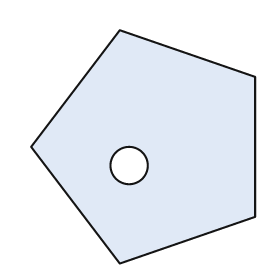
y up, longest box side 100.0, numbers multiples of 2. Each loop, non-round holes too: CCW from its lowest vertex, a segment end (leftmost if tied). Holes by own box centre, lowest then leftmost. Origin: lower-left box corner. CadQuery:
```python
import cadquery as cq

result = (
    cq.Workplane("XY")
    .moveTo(38.0, 0.0)
    .lineTo(96.0, 20.0)
    .lineTo(96.0, 80.0)
    .lineTo(38.0, 100.0)
    .lineTo(0.0, 50.0)
    .close()
    .moveTo(42.0, 42.0)
    .circle(8.0)
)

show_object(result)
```